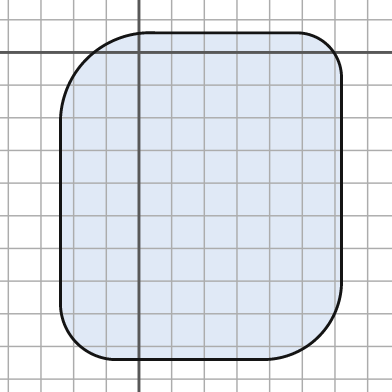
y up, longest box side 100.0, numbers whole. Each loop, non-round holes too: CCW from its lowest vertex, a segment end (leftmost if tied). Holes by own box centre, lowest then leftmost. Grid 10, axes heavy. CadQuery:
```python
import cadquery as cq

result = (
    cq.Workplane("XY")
    .moveTo(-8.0, -94.0)
    .lineTo(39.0, -94.0)
    .threePointArc((55.0, -87.0), (62.0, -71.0))
    .lineTo(62.0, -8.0)
    .threePointArc((58.0, 2.0), (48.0, 6.0))
    .lineTo(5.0, 6.0)
    .threePointArc((-16.0, -2.0), (-24.0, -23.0))
    .lineTo(-24.0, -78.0)
    .threePointArc((-19.0, -89.0), (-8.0, -94.0))
    .close()
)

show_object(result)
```